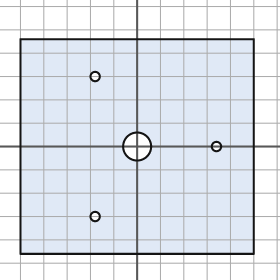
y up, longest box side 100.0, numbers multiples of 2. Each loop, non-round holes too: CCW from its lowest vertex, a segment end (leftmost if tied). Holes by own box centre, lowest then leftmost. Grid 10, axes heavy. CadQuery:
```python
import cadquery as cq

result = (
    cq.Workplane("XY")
    .moveTo(-50.0, -46.0)
    .lineTo(50.0, -46.0)
    .lineTo(50.0, 46.0)
    .lineTo(-50.0, 46.0)
    .close()
    .moveTo(-18.0, -30.0)
    .circle(2.0)
    .moveTo(0.0, 0.0)
    .circle(6.0)
    .moveTo(34.0, 0.0)
    .circle(2.0)
    .moveTo(-18.0, 30.0)
    .circle(2.0)
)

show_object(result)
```